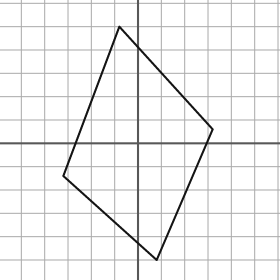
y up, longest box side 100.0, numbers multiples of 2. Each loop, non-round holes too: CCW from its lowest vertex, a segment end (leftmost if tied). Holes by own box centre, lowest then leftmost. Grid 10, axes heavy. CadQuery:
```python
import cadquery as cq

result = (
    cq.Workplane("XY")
    .moveTo(8.0, -50.0)
    .lineTo(32.0, 6.0)
    .lineTo(-8.0, 50.0)
    .lineTo(-32.0, -14.0)
    .close()
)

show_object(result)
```